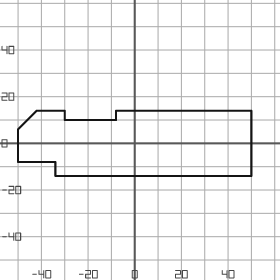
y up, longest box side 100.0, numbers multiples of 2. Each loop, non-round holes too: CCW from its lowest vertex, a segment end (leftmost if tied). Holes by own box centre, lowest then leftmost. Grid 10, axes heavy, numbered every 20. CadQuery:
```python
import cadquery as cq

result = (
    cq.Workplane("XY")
    .moveTo(-34.0, -14.0)
    .lineTo(50.0, -14.0)
    .lineTo(50.0, 14.0)
    .lineTo(-8.0, 14.0)
    .lineTo(-8.0, 10.0)
    .lineTo(-30.0, 10.0)
    .lineTo(-30.0, 14.0)
    .lineTo(-42.0, 14.0)
    .lineTo(-50.0, 6.0)
    .lineTo(-50.0, -8.0)
    .lineTo(-34.0, -8.0)
    .close()
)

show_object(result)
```